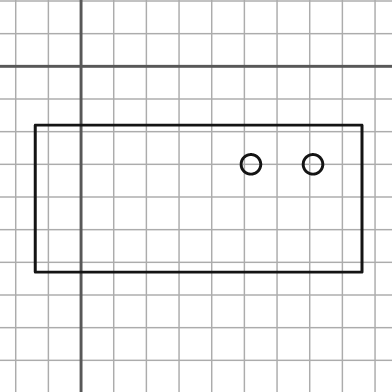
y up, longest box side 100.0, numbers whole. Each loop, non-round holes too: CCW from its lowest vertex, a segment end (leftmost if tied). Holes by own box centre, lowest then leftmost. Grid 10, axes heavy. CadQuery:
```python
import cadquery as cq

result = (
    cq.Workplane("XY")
    .moveTo(-14.0, -63.0)
    .lineTo(86.0, -63.0)
    .lineTo(86.0, -18.0)
    .lineTo(-14.0, -18.0)
    .close()
    .moveTo(52.0, -30.0)
    .circle(3.0)
    .moveTo(71.0, -30.0)
    .circle(3.0)
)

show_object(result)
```